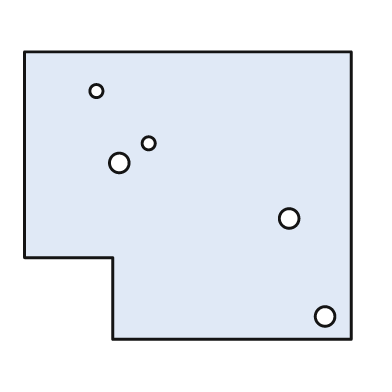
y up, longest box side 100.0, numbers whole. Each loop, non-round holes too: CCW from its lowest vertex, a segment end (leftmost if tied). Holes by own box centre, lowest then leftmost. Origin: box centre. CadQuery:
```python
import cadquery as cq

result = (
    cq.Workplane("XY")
    .moveTo(-23.0, -44.0)
    .lineTo(50.0, -44.0)
    .lineTo(50.0, 44.0)
    .lineTo(-50.0, 44.0)
    .lineTo(-50.0, -19.0)
    .lineTo(-23.0, -19.0)
    .close()
    .moveTo(42.0, -37.0)
    .circle(3.0)
    .moveTo(31.0, -7.0)
    .circle(3.0)
    .moveTo(-21.0, 10.0)
    .circle(3.0)
    .moveTo(-12.0, 16.0)
    .circle(2.0)
    .moveTo(-28.0, 32.0)
    .circle(2.0)
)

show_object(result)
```